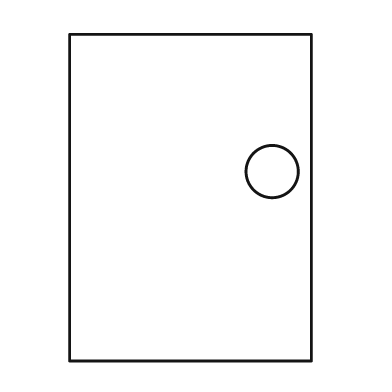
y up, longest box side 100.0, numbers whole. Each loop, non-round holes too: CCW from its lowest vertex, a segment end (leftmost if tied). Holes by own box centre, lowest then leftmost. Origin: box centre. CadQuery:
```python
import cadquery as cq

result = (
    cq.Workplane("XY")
    .moveTo(-37.0, -50.0)
    .lineTo(37.0, -50.0)
    .lineTo(37.0, 50.0)
    .lineTo(-37.0, 50.0)
    .close()
    .moveTo(25.0, 8.0)
    .circle(8.0)
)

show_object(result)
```